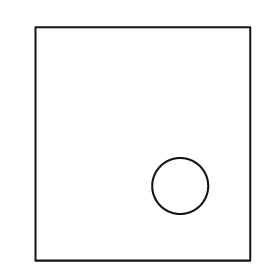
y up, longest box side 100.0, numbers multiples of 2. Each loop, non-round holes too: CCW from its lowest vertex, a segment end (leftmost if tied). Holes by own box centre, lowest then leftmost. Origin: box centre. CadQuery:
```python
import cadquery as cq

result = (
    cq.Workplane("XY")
    .moveTo(-46.0, -50.0)
    .lineTo(46.0, -50.0)
    .lineTo(46.0, 50.0)
    .lineTo(-46.0, 50.0)
    .close()
    .moveTo(16.0, -18.0)
    .circle(12.0)
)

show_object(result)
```